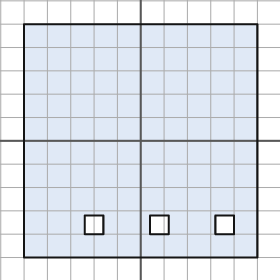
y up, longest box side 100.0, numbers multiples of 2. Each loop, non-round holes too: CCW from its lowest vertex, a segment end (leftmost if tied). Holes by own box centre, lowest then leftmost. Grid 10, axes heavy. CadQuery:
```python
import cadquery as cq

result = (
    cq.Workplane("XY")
    .moveTo(-50.0, -50.0)
    .lineTo(50.0, -50.0)
    .lineTo(50.0, 50.0)
    .lineTo(-50.0, 50.0)
    .close()
    .moveTo(-24.0, -40.0)
    .lineTo(-16.0, -40.0)
    .lineTo(-16.0, -32.0)
    .lineTo(-24.0, -32.0)
    .close()
    .moveTo(4.0, -40.0)
    .lineTo(12.0, -40.0)
    .lineTo(12.0, -32.0)
    .lineTo(4.0, -32.0)
    .close()
    .moveTo(32.0, -40.0)
    .lineTo(40.0, -40.0)
    .lineTo(40.0, -32.0)
    .lineTo(32.0, -32.0)
    .close()
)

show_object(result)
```